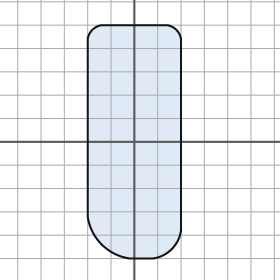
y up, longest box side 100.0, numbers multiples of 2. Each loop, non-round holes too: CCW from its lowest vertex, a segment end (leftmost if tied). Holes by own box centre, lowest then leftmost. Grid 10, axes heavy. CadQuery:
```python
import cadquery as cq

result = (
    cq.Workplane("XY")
    .moveTo(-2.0, -50.0)
    .lineTo(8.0, -50.0)
    .threePointArc((16.0, -46.0), (20.0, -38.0))
    .lineTo(20.0, 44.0)
    .threePointArc((18.0, 48.0), (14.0, 50.0))
    .lineTo(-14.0, 50.0)
    .threePointArc((-18.0, 48.0), (-20.0, 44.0))
    .lineTo(-20.0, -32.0)
    .threePointArc((-14.0, -44.0), (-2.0, -50.0))
    .close()
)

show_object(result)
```